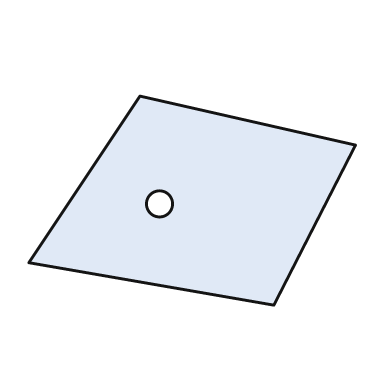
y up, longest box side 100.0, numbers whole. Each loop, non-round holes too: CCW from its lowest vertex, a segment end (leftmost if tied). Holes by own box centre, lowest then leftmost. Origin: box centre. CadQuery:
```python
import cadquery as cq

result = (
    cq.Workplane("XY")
    .moveTo(25.0, -32.0)
    .lineTo(50.0, 17.0)
    .lineTo(-16.0, 32.0)
    .lineTo(-50.0, -19.0)
    .close()
    .moveTo(-10.0, -1.0)
    .circle(4.0)
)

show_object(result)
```